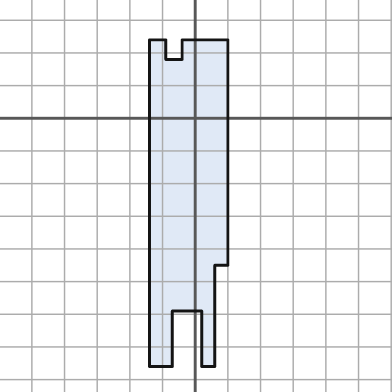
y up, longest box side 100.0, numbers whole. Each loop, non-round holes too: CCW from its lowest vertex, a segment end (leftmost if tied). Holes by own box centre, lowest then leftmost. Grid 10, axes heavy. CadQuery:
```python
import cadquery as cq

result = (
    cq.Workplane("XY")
    .moveTo(-14.0, -76.0)
    .lineTo(-7.0, -76.0)
    .lineTo(-7.0, -59.0)
    .lineTo(2.0, -59.0)
    .lineTo(2.0, -76.0)
    .lineTo(6.0, -76.0)
    .lineTo(6.0, -45.0)
    .lineTo(10.0, -45.0)
    .lineTo(10.0, 24.0)
    .lineTo(-4.0, 24.0)
    .lineTo(-4.0, 18.0)
    .lineTo(-9.0, 18.0)
    .lineTo(-9.0, 24.0)
    .lineTo(-14.0, 24.0)
    .close()
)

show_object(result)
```